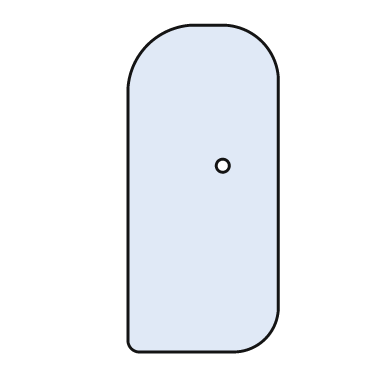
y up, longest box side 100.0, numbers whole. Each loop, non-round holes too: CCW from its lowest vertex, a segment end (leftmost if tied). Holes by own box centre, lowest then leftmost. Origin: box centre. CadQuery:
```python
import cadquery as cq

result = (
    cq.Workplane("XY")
    .moveTo(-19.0, -50.0)
    .lineTo(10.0, -50.0)
    .threePointArc((19.0, -46.0), (23.0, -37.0))
    .lineTo(23.0, 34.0)
    .threePointArc((18.0, 45.0), (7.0, 50.0))
    .lineTo(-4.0, 50.0)
    .threePointArc((-17.0, 44.0), (-23.0, 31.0))
    .lineTo(-23.0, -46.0)
    .threePointArc((-22.0, -49.0), (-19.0, -50.0))
    .close()
    .moveTo(6.0, 7.0)
    .circle(2.0)
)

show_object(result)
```